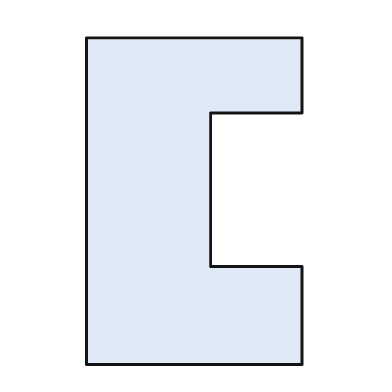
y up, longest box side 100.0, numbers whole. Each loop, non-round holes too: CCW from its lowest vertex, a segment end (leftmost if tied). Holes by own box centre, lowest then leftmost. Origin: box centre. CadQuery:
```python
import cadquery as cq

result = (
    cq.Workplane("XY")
    .moveTo(-33.0, -50.0)
    .lineTo(33.0, -50.0)
    .lineTo(33.0, -20.0)
    .lineTo(5.0, -20.0)
    .lineTo(5.0, 27.0)
    .lineTo(33.0, 27.0)
    .lineTo(33.0, 50.0)
    .lineTo(-33.0, 50.0)
    .close()
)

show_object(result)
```